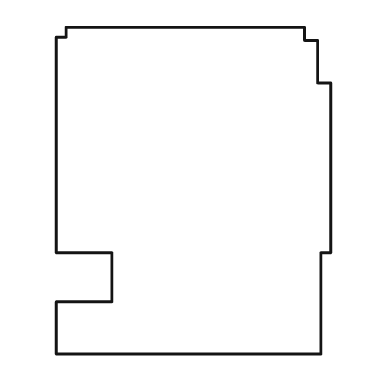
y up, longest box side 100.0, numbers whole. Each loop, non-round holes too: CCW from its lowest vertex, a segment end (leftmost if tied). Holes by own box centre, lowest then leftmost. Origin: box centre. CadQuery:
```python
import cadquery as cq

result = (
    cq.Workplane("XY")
    .moveTo(-42.0, -50.0)
    .lineTo(39.0, -50.0)
    .lineTo(39.0, -19.0)
    .lineTo(42.0, -19.0)
    .lineTo(42.0, 33.0)
    .lineTo(38.0, 33.0)
    .lineTo(38.0, 46.0)
    .lineTo(34.0, 46.0)
    .lineTo(34.0, 50.0)
    .lineTo(-39.0, 50.0)
    .lineTo(-39.0, 47.0)
    .lineTo(-42.0, 47.0)
    .lineTo(-42.0, -19.0)
    .lineTo(-25.0, -19.0)
    .lineTo(-25.0, -34.0)
    .lineTo(-42.0, -34.0)
    .close()
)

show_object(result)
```